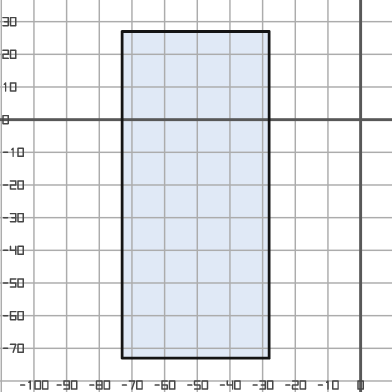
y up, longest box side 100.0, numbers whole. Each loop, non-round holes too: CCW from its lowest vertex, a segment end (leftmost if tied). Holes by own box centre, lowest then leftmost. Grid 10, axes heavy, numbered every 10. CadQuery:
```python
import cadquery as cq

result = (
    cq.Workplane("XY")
    .moveTo(-73.0, -73.0)
    .lineTo(-28.0, -73.0)
    .lineTo(-28.0, 27.0)
    .lineTo(-73.0, 27.0)
    .close()
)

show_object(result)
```